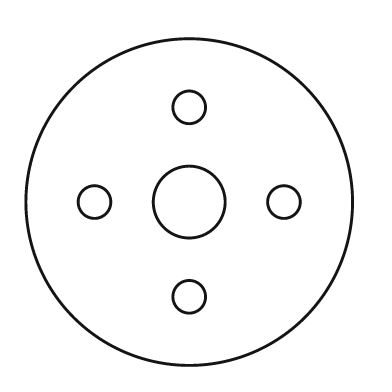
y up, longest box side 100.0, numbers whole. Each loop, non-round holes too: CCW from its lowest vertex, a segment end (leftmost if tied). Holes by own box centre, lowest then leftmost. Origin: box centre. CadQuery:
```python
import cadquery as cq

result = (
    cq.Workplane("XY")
    .moveTo(0.0, 0.0)
    .circle(50.0)
    .moveTo(0.0, -29.0)
    .circle(5.0)
    .moveTo(-29.0, 0.0)
    .circle(5.0)
    .moveTo(0.0, 0.0)
    .circle(11.0)
    .moveTo(29.0, 0.0)
    .circle(5.0)
    .moveTo(0.0, 29.0)
    .circle(5.0)
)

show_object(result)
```